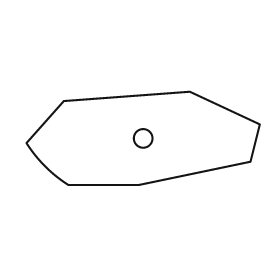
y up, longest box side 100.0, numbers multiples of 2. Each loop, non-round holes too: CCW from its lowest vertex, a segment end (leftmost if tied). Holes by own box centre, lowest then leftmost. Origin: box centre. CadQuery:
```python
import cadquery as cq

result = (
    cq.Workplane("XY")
    .moveTo(-32.0, -20.0)
    .lineTo(-2.0, -20.0)
    .lineTo(46.0, -10.0)
    .lineTo(50.0, 6.0)
    .lineTo(20.0, 20.0)
    .lineTo(-34.0, 16.0)
    .lineTo(-50.0, -2.0)
    .threePointArc((-42.0, -12.0), (-32.0, -20.0))
    .close()
    .moveTo(0.0, 0.0)
    .circle(4.0)
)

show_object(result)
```